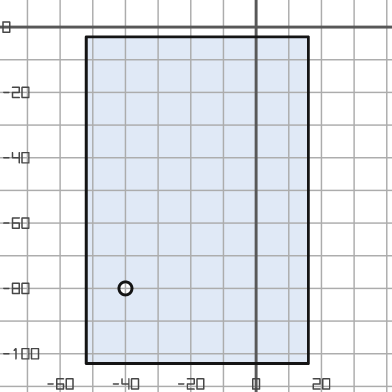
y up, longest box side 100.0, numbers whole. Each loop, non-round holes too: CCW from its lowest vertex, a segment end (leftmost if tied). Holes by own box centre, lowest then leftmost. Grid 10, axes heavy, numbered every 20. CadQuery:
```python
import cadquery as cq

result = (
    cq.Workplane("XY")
    .moveTo(-52.0, -103.0)
    .lineTo(16.0, -103.0)
    .lineTo(16.0, -3.0)
    .lineTo(-52.0, -3.0)
    .close()
    .moveTo(-40.0, -80.0)
    .circle(2.0)
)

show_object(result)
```